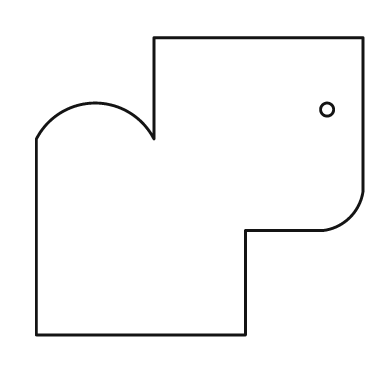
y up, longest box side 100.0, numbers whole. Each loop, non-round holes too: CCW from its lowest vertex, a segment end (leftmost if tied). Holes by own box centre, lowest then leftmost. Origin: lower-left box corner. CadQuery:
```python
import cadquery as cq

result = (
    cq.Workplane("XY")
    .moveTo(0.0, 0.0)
    .lineTo(64.0, 0.0)
    .lineTo(64.0, 32.0)
    .lineTo(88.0, 32.0)
    .threePointArc((96.0, 36.0), (100.0, 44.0))
    .lineTo(100.0, 91.0)
    .lineTo(36.0, 91.0)
    .lineTo(36.0, 60.0)
    .threePointArc((18.0, 71.0), (0.0, 60.0))
    .close()
    .moveTo(89.0, 69.0)
    .circle(2.0)
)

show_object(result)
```